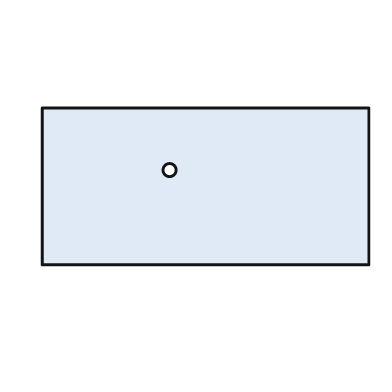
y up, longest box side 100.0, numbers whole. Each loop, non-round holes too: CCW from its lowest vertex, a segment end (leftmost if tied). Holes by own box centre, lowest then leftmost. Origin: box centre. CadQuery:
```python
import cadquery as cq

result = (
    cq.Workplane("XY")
    .moveTo(-50.0, -24.0)
    .lineTo(50.0, -24.0)
    .lineTo(50.0, 24.0)
    .lineTo(-50.0, 24.0)
    .close()
    .moveTo(-11.0, 5.0)
    .circle(2.0)
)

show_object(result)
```